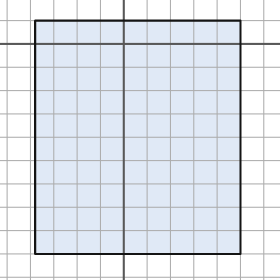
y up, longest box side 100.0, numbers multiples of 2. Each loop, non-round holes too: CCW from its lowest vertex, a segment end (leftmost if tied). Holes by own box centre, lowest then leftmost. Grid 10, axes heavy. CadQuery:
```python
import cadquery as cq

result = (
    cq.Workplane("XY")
    .moveTo(-38.0, -90.0)
    .lineTo(50.0, -90.0)
    .lineTo(50.0, 10.0)
    .lineTo(-38.0, 10.0)
    .close()
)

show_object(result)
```